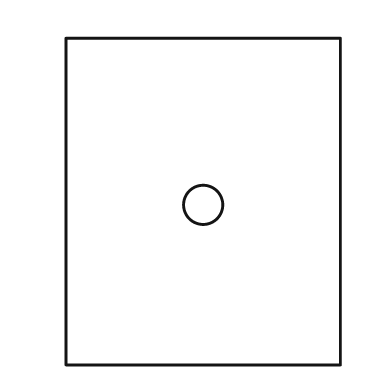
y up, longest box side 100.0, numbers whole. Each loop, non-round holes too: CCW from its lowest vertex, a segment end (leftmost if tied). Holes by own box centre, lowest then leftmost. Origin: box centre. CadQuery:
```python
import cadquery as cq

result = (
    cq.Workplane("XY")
    .moveTo(-42.0, -50.0)
    .lineTo(42.0, -50.0)
    .lineTo(42.0, 50.0)
    .lineTo(-42.0, 50.0)
    .close()
    .moveTo(0.0, -1.0)
    .circle(6.0)
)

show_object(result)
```